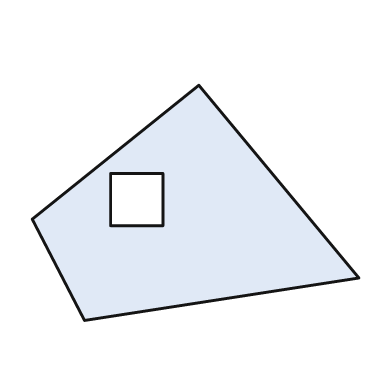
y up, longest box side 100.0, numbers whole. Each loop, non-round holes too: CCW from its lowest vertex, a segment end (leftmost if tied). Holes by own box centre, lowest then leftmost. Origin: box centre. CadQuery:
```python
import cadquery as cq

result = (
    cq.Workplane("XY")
    .moveTo(-34.0, -36.0)
    .lineTo(50.0, -23.0)
    .lineTo(1.0, 36.0)
    .lineTo(-50.0, -5.0)
    .close()
    .moveTo(-26.0, -7.0)
    .lineTo(-10.0, -7.0)
    .lineTo(-10.0, 9.0)
    .lineTo(-26.0, 9.0)
    .close()
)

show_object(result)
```